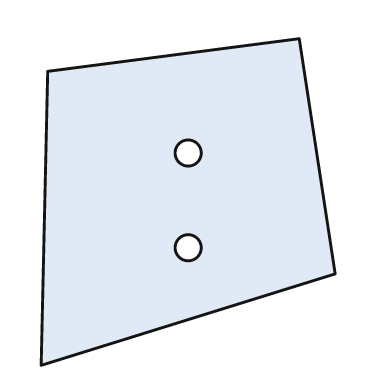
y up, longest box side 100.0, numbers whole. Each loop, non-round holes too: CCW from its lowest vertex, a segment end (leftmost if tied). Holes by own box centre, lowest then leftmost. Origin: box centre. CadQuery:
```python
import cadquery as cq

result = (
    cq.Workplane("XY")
    .moveTo(-45.0, -50.0)
    .lineTo(45.0, -22.0)
    .lineTo(34.0, 50.0)
    .lineTo(-43.0, 40.0)
    .close()
    .moveTo(0.0, -14.0)
    .circle(4.0)
    .moveTo(0.0, 15.0)
    .circle(4.0)
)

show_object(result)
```